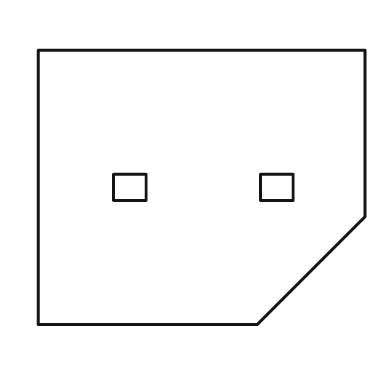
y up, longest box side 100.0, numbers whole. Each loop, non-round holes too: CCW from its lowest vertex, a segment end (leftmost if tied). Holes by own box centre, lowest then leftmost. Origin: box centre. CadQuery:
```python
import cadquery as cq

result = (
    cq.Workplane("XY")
    .moveTo(-50.0, -42.0)
    .lineTo(17.0, -42.0)
    .lineTo(50.0, -9.0)
    .lineTo(50.0, 42.0)
    .lineTo(-50.0, 42.0)
    .close()
    .moveTo(-27.0, -4.0)
    .lineTo(-17.0, -4.0)
    .lineTo(-17.0, 4.0)
    .lineTo(-27.0, 4.0)
    .close()
    .moveTo(18.0, -4.0)
    .lineTo(28.0, -4.0)
    .lineTo(28.0, 4.0)
    .lineTo(18.0, 4.0)
    .close()
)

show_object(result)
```